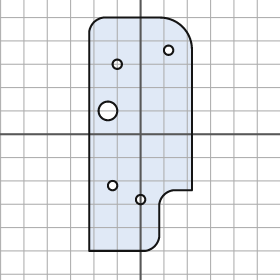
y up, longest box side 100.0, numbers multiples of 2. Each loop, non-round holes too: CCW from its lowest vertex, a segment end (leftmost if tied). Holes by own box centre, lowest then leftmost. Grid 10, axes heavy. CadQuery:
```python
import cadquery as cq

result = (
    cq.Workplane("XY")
    .moveTo(-22.0, -50.0)
    .lineTo(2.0, -50.0)
    .threePointArc((6.0, -48.0), (8.0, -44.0))
    .lineTo(8.0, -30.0)
    .threePointArc((10.0, -26.0), (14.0, -24.0))
    .lineTo(22.0, -24.0)
    .lineTo(22.0, 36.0)
    .threePointArc((18.0, 46.0), (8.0, 50.0))
    .lineTo(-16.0, 50.0)
    .threePointArc((-20.0, 48.0), (-22.0, 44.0))
    .close()
    .moveTo(0.0, -28.0)
    .circle(2.0)
    .moveTo(-12.0, -22.0)
    .circle(2.0)
    .moveTo(-14.0, 10.0)
    .circle(4.0)
    .moveTo(-10.0, 30.0)
    .circle(2.0)
    .moveTo(12.0, 36.0)
    .circle(2.0)
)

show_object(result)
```